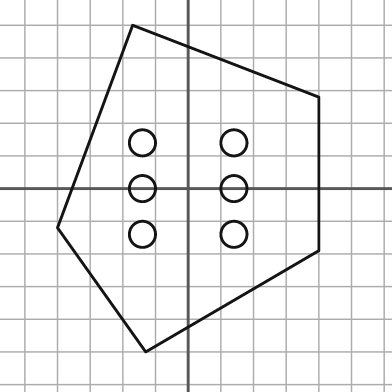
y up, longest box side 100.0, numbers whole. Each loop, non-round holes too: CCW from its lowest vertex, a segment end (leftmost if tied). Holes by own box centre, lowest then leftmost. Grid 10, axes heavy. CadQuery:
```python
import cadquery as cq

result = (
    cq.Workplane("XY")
    .moveTo(-13.0, -50.0)
    .lineTo(40.0, -19.0)
    .lineTo(40.0, 28.0)
    .lineTo(-17.0, 50.0)
    .lineTo(-40.0, -12.0)
    .close()
    .moveTo(-14.0, -14.0)
    .circle(4.0)
    .moveTo(14.0, -14.0)
    .circle(4.0)
    .moveTo(-14.0, 0.0)
    .circle(4.0)
    .moveTo(14.0, 0.0)
    .circle(4.0)
    .moveTo(-14.0, 14.0)
    .circle(4.0)
    .moveTo(14.0, 14.0)
    .circle(4.0)
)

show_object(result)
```